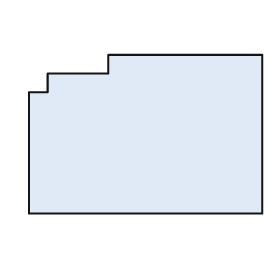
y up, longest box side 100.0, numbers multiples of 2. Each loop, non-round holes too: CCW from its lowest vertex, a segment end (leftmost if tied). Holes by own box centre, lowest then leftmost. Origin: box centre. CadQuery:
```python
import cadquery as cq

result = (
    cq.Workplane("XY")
    .moveTo(-50.0, -34.0)
    .lineTo(50.0, -34.0)
    .lineTo(50.0, 34.0)
    .lineTo(-16.0, 34.0)
    .lineTo(-16.0, 26.0)
    .lineTo(-42.0, 26.0)
    .lineTo(-42.0, 18.0)
    .lineTo(-50.0, 18.0)
    .close()
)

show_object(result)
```